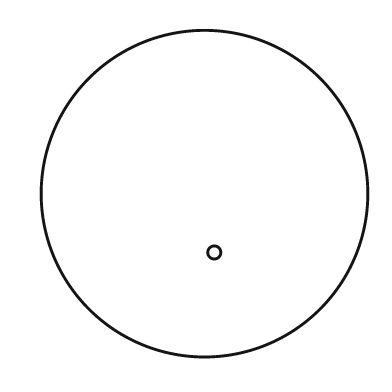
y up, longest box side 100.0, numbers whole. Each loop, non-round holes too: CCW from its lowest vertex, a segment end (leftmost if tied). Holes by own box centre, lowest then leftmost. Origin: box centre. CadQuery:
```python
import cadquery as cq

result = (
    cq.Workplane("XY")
    .moveTo(0.0, 0.0)
    .circle(50.0)
    .moveTo(3.0, -18.0)
    .circle(2.0)
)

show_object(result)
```